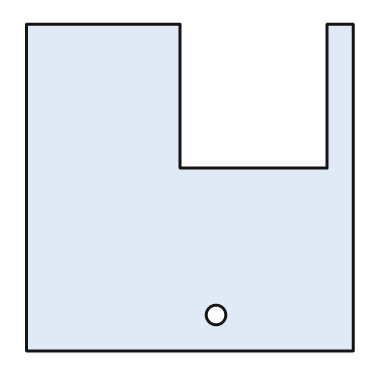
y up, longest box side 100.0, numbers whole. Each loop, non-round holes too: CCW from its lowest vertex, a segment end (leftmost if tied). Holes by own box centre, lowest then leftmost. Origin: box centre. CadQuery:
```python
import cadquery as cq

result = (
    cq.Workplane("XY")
    .moveTo(-50.0, -50.0)
    .lineTo(50.0, -50.0)
    .lineTo(50.0, 50.0)
    .lineTo(42.0, 50.0)
    .lineTo(42.0, 6.0)
    .lineTo(-3.0, 6.0)
    .lineTo(-3.0, 50.0)
    .lineTo(-50.0, 50.0)
    .close()
    .moveTo(8.0, -39.0)
    .circle(3.0)
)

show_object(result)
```